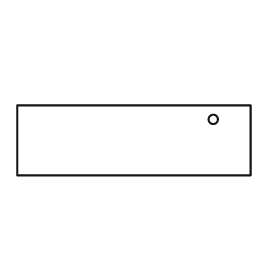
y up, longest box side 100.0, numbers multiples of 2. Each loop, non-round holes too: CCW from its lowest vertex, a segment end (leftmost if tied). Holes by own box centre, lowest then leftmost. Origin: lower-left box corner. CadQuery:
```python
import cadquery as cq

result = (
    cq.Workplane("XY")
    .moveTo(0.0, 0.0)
    .lineTo(100.0, 0.0)
    .lineTo(100.0, 30.0)
    .lineTo(0.0, 30.0)
    .close()
    .moveTo(84.0, 24.0)
    .circle(2.0)
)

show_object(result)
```